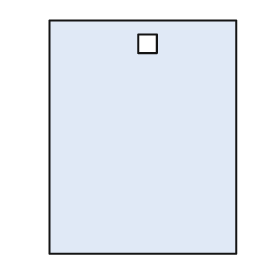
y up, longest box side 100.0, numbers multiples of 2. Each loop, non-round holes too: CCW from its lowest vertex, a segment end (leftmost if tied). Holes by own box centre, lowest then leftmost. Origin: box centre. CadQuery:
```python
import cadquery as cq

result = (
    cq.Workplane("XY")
    .moveTo(-40.0, -50.0)
    .lineTo(40.0, -50.0)
    .lineTo(40.0, 50.0)
    .lineTo(-40.0, 50.0)
    .close()
    .moveTo(-2.0, 36.0)
    .lineTo(6.0, 36.0)
    .lineTo(6.0, 44.0)
    .lineTo(-2.0, 44.0)
    .close()
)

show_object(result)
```